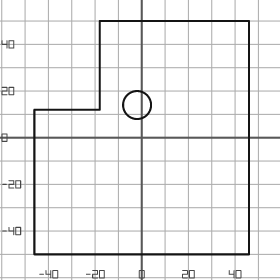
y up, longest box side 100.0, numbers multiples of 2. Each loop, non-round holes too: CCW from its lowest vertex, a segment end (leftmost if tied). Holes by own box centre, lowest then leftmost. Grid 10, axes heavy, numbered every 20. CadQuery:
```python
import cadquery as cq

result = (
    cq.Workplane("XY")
    .moveTo(-46.0, -50.0)
    .lineTo(46.0, -50.0)
    .lineTo(46.0, 50.0)
    .lineTo(-18.0, 50.0)
    .lineTo(-18.0, 12.0)
    .lineTo(-46.0, 12.0)
    .close()
    .moveTo(-2.0, 14.0)
    .circle(6.0)
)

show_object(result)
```